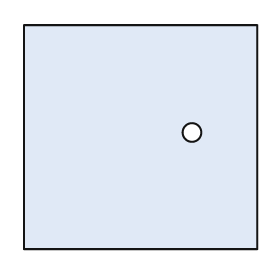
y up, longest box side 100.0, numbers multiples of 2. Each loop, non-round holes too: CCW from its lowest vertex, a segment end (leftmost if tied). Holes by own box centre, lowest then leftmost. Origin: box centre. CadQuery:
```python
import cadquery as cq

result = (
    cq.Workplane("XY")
    .moveTo(-50.0, -48.0)
    .lineTo(50.0, -48.0)
    .lineTo(50.0, 48.0)
    .lineTo(-50.0, 48.0)
    .close()
    .moveTo(22.0, 2.0)
    .circle(4.0)
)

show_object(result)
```